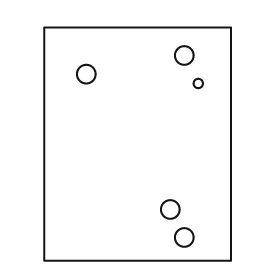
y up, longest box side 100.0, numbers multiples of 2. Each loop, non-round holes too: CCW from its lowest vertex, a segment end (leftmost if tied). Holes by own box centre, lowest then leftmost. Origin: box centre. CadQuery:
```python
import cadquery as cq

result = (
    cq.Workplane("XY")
    .moveTo(-40.0, -50.0)
    .lineTo(40.0, -50.0)
    .lineTo(40.0, 50.0)
    .lineTo(-40.0, 50.0)
    .close()
    .moveTo(20.0, -40.0)
    .circle(4.0)
    .moveTo(14.0, -28.0)
    .circle(4.0)
    .moveTo(26.0, 26.0)
    .circle(2.0)
    .moveTo(-22.0, 30.0)
    .circle(4.0)
    .moveTo(20.0, 38.0)
    .circle(4.0)
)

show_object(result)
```